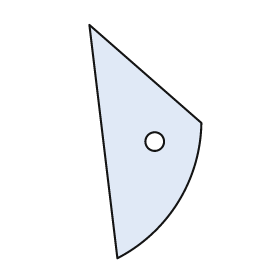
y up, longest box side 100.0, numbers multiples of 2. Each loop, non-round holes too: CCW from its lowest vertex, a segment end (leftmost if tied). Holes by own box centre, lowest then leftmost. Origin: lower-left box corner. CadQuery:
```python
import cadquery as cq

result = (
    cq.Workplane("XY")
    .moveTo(12.0, 0.0)
    .threePointArc((38.0, 24.0), (48.0, 58.0))
    .lineTo(0.0, 100.0)
    .close()
    .moveTo(28.0, 50.0)
    .circle(4.0)
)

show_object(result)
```